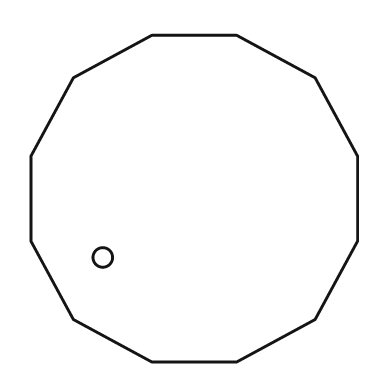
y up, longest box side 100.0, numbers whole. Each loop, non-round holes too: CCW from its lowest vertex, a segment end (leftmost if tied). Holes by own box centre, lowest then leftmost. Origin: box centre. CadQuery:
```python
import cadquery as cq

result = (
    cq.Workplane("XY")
    .moveTo(-13.0, -50.0)
    .lineTo(13.0, -50.0)
    .lineTo(37.0, -37.0)
    .lineTo(50.0, -13.0)
    .lineTo(50.0, 13.0)
    .lineTo(37.0, 37.0)
    .lineTo(13.0, 50.0)
    .lineTo(-13.0, 50.0)
    .lineTo(-37.0, 37.0)
    .lineTo(-50.0, 13.0)
    .lineTo(-50.0, -13.0)
    .lineTo(-37.0, -37.0)
    .close()
    .moveTo(-28.0, -18.0)
    .circle(3.0)
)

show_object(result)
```